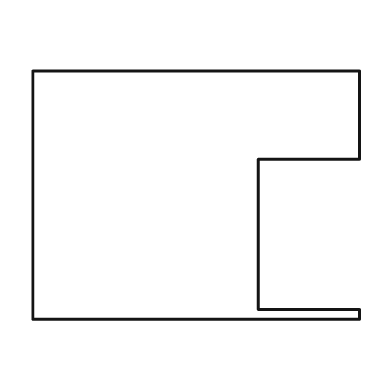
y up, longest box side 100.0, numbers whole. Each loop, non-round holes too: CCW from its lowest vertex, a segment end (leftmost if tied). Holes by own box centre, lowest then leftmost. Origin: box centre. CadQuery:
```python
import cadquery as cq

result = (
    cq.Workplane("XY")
    .moveTo(-50.0, -38.0)
    .lineTo(50.0, -38.0)
    .lineTo(50.0, -35.0)
    .lineTo(19.0, -35.0)
    .lineTo(19.0, 11.0)
    .lineTo(50.0, 11.0)
    .lineTo(50.0, 38.0)
    .lineTo(-50.0, 38.0)
    .close()
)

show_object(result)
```